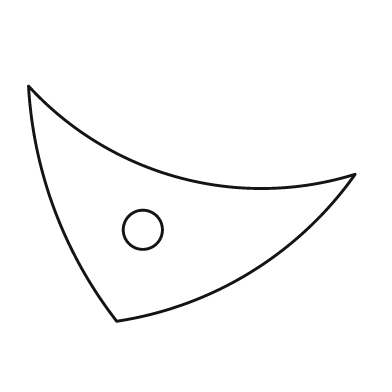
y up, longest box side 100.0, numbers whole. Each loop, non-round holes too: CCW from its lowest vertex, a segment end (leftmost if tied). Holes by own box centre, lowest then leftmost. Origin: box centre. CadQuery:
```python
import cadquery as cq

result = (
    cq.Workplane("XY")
    .moveTo(-23.0, -36.0)
    .threePointArc((18.0, -21.0), (50.0, 9.0))
    .threePointArc((-4.0, 8.0), (-50.0, 36.0))
    .threePointArc((-42.0, -2.0), (-23.0, -36.0))
    .close()
    .moveTo(-15.0, -8.0)
    .circle(6.0)
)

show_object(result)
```